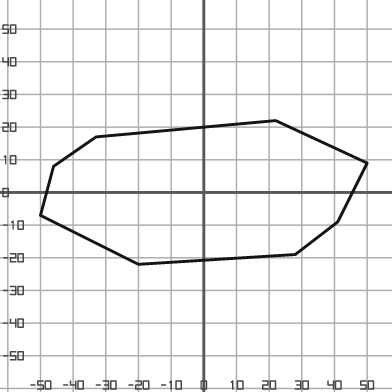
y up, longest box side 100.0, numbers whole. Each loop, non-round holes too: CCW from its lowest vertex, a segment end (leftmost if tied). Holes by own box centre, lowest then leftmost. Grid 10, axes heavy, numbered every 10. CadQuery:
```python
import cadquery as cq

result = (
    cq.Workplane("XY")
    .moveTo(-20.0, -22.0)
    .lineTo(28.0, -19.0)
    .lineTo(41.0, -9.0)
    .lineTo(50.0, 9.0)
    .lineTo(22.0, 22.0)
    .lineTo(-33.0, 17.0)
    .lineTo(-46.0, 8.0)
    .lineTo(-50.0, -7.0)
    .close()
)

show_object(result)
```